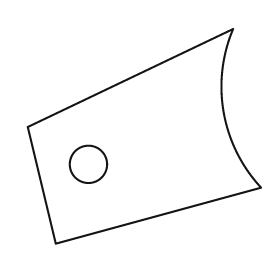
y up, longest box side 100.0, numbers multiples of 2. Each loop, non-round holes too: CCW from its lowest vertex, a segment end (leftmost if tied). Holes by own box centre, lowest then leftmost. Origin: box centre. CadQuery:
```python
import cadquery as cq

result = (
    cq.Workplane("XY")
    .moveTo(-38.0, -46.0)
    .lineTo(50.0, -22.0)
    .threePointArc((34.0, 10.0), (38.0, 46.0))
    .lineTo(-50.0, 4.0)
    .close()
    .moveTo(-24.0, -12.0)
    .circle(8.0)
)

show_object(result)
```